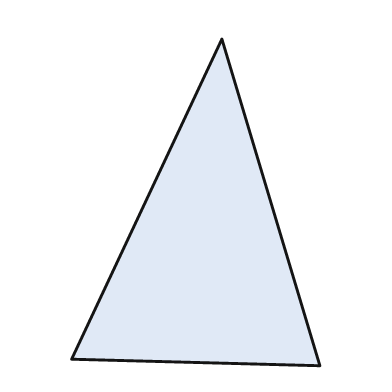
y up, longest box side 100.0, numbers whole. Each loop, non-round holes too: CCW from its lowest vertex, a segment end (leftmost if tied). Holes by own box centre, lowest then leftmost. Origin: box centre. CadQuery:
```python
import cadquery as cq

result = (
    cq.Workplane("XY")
    .moveTo(38.0, -50.0)
    .lineTo(8.0, 50.0)
    .lineTo(-38.0, -48.0)
    .close()
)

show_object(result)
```